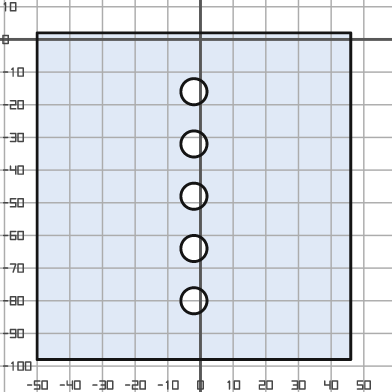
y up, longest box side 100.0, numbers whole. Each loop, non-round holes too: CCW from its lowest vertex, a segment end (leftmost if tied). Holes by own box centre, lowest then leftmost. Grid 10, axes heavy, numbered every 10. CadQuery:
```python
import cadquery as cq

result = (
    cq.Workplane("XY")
    .moveTo(-50.0, -98.0)
    .lineTo(46.0, -98.0)
    .lineTo(46.0, 2.0)
    .lineTo(-50.0, 2.0)
    .close()
    .moveTo(-2.0, -80.0)
    .circle(4.0)
    .moveTo(-2.0, -64.0)
    .circle(4.0)
    .moveTo(-2.0, -48.0)
    .circle(4.0)
    .moveTo(-2.0, -32.0)
    .circle(4.0)
    .moveTo(-2.0, -16.0)
    .circle(4.0)
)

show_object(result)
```